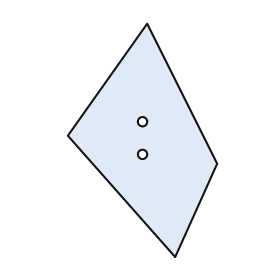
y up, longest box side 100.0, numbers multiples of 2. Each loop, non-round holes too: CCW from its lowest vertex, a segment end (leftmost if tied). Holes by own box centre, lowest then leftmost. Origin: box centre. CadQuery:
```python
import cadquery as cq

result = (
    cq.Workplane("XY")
    .moveTo(14.0, -50.0)
    .lineTo(32.0, -10.0)
    .lineTo(2.0, 50.0)
    .lineTo(-32.0, 2.0)
    .close()
    .moveTo(0.0, -6.0)
    .circle(2.0)
    .moveTo(0.0, 8.0)
    .circle(2.0)
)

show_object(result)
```